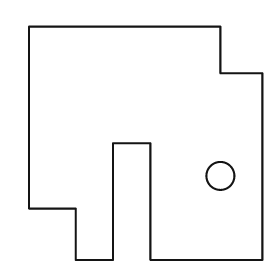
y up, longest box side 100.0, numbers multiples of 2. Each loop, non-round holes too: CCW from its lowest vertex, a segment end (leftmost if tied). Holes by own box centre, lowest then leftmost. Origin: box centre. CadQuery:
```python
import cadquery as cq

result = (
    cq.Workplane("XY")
    .moveTo(-30.0, -50.0)
    .lineTo(-14.0, -50.0)
    .lineTo(-14.0, 0.0)
    .lineTo(2.0, 0.0)
    .lineTo(2.0, -50.0)
    .lineTo(50.0, -50.0)
    .lineTo(50.0, 30.0)
    .lineTo(32.0, 30.0)
    .lineTo(32.0, 50.0)
    .lineTo(-50.0, 50.0)
    .lineTo(-50.0, -28.0)
    .lineTo(-30.0, -28.0)
    .close()
    .moveTo(32.0, -14.0)
    .circle(6.0)
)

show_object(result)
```